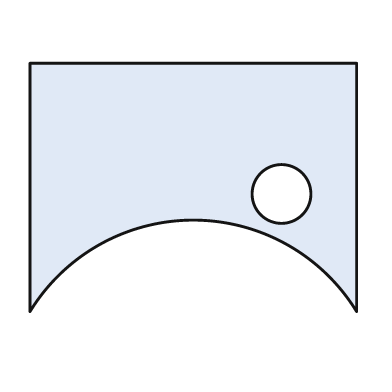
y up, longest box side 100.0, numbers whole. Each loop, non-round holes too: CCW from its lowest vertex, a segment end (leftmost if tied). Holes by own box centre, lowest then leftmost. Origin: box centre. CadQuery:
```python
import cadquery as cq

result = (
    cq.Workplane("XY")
    .moveTo(-50.0, -38.0)
    .threePointArc((0.0, -10.0), (50.0, -38.0))
    .lineTo(50.0, 38.0)
    .lineTo(-50.0, 38.0)
    .close()
    .moveTo(27.0, -2.0)
    .circle(9.0)
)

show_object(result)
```